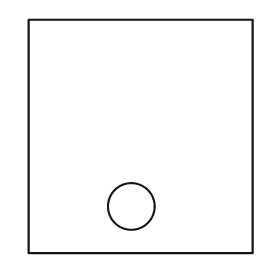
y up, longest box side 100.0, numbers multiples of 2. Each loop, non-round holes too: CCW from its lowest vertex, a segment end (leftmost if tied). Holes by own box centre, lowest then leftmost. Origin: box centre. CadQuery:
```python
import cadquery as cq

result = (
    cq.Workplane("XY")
    .moveTo(-48.0, -50.0)
    .lineTo(48.0, -50.0)
    .lineTo(48.0, 50.0)
    .lineTo(-48.0, 50.0)
    .close()
    .moveTo(-4.0, -30.0)
    .circle(10.0)
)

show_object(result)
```